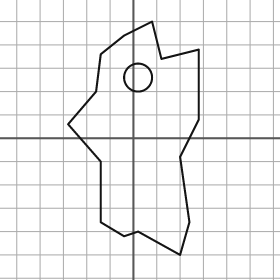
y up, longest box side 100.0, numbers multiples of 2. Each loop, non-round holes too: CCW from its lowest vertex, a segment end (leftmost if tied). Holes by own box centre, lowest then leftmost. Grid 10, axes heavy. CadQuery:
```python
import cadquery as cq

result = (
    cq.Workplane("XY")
    .moveTo(20.0, -50.0)
    .lineTo(24.0, -36.0)
    .lineTo(20.0, -8.0)
    .lineTo(28.0, 8.0)
    .lineTo(28.0, 38.0)
    .lineTo(12.0, 34.0)
    .lineTo(8.0, 50.0)
    .lineTo(-4.0, 44.0)
    .lineTo(-14.0, 36.0)
    .lineTo(-16.0, 20.0)
    .lineTo(-28.0, 6.0)
    .lineTo(-14.0, -10.0)
    .lineTo(-14.0, -36.0)
    .lineTo(-4.0, -42.0)
    .lineTo(2.0, -40.0)
    .close()
    .moveTo(2.0, 26.0)
    .circle(6.0)
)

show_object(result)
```